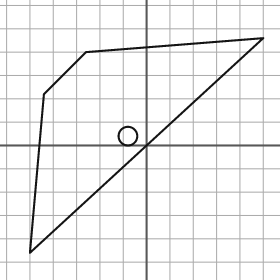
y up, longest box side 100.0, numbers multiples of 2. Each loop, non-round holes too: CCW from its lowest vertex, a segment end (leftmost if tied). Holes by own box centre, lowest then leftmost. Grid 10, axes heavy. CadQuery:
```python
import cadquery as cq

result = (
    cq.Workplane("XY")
    .moveTo(-50.0, -46.0)
    .lineTo(50.0, 46.0)
    .lineTo(-26.0, 40.0)
    .lineTo(-44.0, 22.0)
    .close()
    .moveTo(-8.0, 4.0)
    .circle(4.0)
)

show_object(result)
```